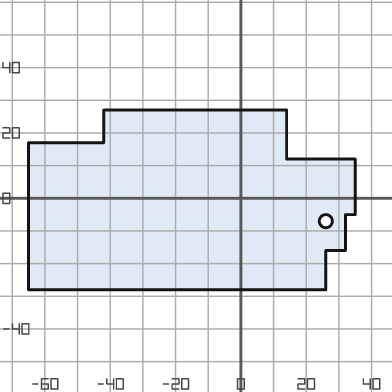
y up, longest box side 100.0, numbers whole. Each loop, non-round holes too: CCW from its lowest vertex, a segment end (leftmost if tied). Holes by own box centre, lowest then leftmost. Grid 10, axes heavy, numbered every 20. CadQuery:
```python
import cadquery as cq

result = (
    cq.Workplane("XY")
    .moveTo(-65.0, -28.0)
    .lineTo(26.0, -28.0)
    .lineTo(26.0, -16.0)
    .lineTo(32.0, -16.0)
    .lineTo(32.0, -5.0)
    .lineTo(35.0, -5.0)
    .lineTo(35.0, 12.0)
    .lineTo(14.0, 12.0)
    .lineTo(14.0, 27.0)
    .lineTo(-42.0, 27.0)
    .lineTo(-42.0, 17.0)
    .lineTo(-65.0, 17.0)
    .close()
    .moveTo(26.0, -7.0)
    .circle(2.0)
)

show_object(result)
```